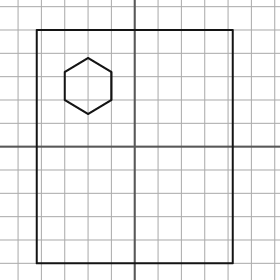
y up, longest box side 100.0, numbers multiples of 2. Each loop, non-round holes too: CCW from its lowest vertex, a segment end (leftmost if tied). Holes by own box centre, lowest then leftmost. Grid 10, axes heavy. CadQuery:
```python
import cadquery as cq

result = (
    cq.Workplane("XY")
    .moveTo(-42.0, -50.0)
    .lineTo(42.0, -50.0)
    .lineTo(42.0, 50.0)
    .lineTo(-42.0, 50.0)
    .close()
    .moveTo(-20.0, 14.0)
    .lineTo(-10.0, 20.0)
    .lineTo(-10.0, 32.0)
    .lineTo(-20.0, 38.0)
    .lineTo(-30.0, 32.0)
    .lineTo(-30.0, 20.0)
    .close()
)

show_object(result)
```